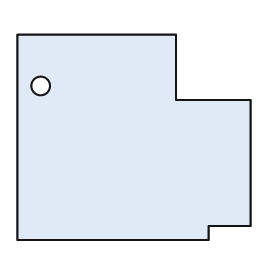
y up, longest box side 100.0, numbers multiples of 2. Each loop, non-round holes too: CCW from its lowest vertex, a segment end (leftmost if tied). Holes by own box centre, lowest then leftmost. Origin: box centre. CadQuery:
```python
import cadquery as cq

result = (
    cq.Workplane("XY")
    .moveTo(-50.0, -44.0)
    .lineTo(32.0, -44.0)
    .lineTo(32.0, -38.0)
    .lineTo(50.0, -38.0)
    .lineTo(50.0, 16.0)
    .lineTo(18.0, 16.0)
    .lineTo(18.0, 44.0)
    .lineTo(-50.0, 44.0)
    .close()
    .moveTo(-40.0, 22.0)
    .circle(4.0)
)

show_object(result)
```